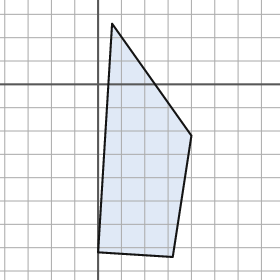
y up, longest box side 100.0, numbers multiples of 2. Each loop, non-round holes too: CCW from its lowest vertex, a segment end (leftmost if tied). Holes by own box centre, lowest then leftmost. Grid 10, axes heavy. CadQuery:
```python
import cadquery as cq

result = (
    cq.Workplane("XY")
    .moveTo(32.0, -74.0)
    .lineTo(40.0, -22.0)
    .lineTo(6.0, 26.0)
    .lineTo(0.0, -72.0)
    .close()
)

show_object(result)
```